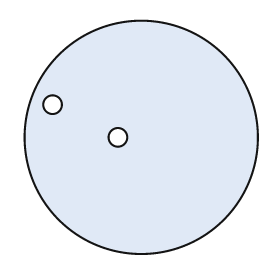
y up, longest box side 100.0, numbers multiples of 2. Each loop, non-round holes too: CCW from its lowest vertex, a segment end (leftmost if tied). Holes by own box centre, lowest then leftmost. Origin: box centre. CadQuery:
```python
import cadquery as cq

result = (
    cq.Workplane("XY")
    .moveTo(0.0, 0.0)
    .circle(50.0)
    .moveTo(-10.0, 0.0)
    .circle(4.0)
    .moveTo(-38.0, 14.0)
    .circle(4.0)
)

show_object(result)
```